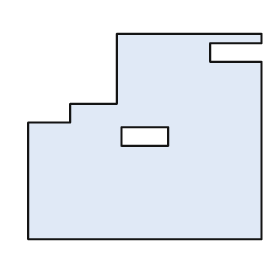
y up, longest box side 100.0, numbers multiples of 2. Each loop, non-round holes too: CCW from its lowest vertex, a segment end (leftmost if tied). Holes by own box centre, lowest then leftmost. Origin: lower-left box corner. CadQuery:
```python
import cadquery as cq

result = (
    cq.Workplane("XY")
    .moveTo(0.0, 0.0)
    .lineTo(100.0, 0.0)
    .lineTo(100.0, 76.0)
    .lineTo(78.0, 76.0)
    .lineTo(78.0, 84.0)
    .lineTo(100.0, 84.0)
    .lineTo(100.0, 88.0)
    .lineTo(38.0, 88.0)
    .lineTo(38.0, 58.0)
    .lineTo(18.0, 58.0)
    .lineTo(18.0, 50.0)
    .lineTo(0.0, 50.0)
    .close()
    .moveTo(40.0, 40.0)
    .lineTo(60.0, 40.0)
    .lineTo(60.0, 48.0)
    .lineTo(40.0, 48.0)
    .close()
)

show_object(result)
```